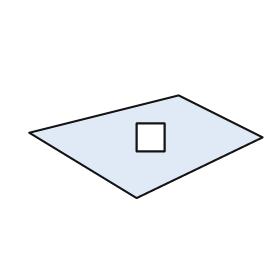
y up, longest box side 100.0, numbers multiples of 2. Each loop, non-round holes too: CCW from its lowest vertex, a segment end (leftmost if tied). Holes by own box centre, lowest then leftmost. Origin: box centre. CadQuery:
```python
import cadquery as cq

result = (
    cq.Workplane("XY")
    .moveTo(-4.0, -22.0)
    .lineTo(50.0, 4.0)
    .lineTo(14.0, 22.0)
    .lineTo(-50.0, 6.0)
    .close()
    .moveTo(-4.0, -2.0)
    .lineTo(8.0, -2.0)
    .lineTo(8.0, 10.0)
    .lineTo(-4.0, 10.0)
    .close()
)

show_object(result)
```